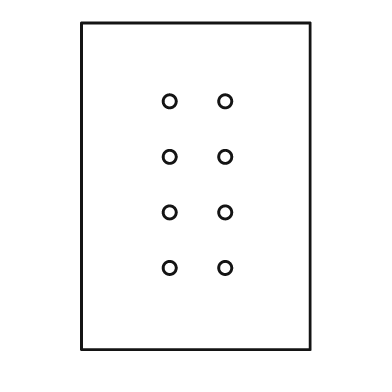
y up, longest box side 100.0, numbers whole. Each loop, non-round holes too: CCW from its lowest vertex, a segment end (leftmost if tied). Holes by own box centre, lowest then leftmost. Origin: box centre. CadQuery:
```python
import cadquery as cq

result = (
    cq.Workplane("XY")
    .moveTo(-35.0, -50.0)
    .lineTo(35.0, -50.0)
    .lineTo(35.0, 50.0)
    .lineTo(-35.0, 50.0)
    .close()
    .moveTo(-8.0, -25.0)
    .circle(2.0)
    .moveTo(9.0, -25.0)
    .circle(2.0)
    .moveTo(-8.0, -8.0)
    .circle(2.0)
    .moveTo(9.0, -8.0)
    .circle(2.0)
    .moveTo(-8.0, 9.0)
    .circle(2.0)
    .moveTo(9.0, 9.0)
    .circle(2.0)
    .moveTo(-8.0, 26.0)
    .circle(2.0)
    .moveTo(9.0, 26.0)
    .circle(2.0)
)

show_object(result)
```